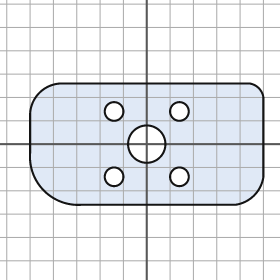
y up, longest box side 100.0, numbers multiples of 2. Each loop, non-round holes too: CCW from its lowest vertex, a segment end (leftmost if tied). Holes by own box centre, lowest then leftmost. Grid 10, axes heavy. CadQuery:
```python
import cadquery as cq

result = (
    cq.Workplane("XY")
    .moveTo(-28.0, -26.0)
    .lineTo(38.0, -26.0)
    .threePointArc((46.0, -22.0), (50.0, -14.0))
    .lineTo(50.0, 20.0)
    .threePointArc((48.0, 24.0), (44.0, 26.0))
    .lineTo(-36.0, 26.0)
    .threePointArc((-46.0, 22.0), (-50.0, 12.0))
    .lineTo(-50.0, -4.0)
    .threePointArc((-44.0, -20.0), (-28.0, -26.0))
    .close()
    .moveTo(-14.0, -14.0)
    .circle(4.0)
    .moveTo(14.0, -14.0)
    .circle(4.0)
    .moveTo(0.0, 0.0)
    .circle(8.0)
    .moveTo(-14.0, 14.0)
    .circle(4.0)
    .moveTo(14.0, 14.0)
    .circle(4.0)
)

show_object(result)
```